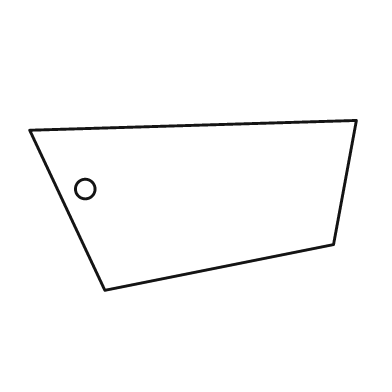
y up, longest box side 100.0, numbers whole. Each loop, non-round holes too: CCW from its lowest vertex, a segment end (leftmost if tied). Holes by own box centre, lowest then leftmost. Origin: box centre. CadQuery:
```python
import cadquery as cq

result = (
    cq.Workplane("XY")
    .moveTo(-27.0, -26.0)
    .lineTo(43.0, -12.0)
    .lineTo(50.0, 26.0)
    .lineTo(-50.0, 23.0)
    .close()
    .moveTo(-33.0, 5.0)
    .circle(3.0)
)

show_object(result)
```